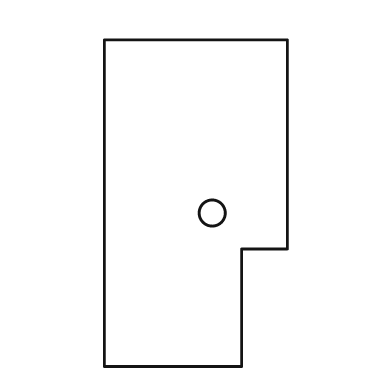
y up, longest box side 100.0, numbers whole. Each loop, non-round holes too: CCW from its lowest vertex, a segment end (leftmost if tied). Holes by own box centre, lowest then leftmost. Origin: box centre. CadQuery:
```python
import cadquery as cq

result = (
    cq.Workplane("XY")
    .moveTo(-28.0, -50.0)
    .lineTo(14.0, -50.0)
    .lineTo(14.0, -14.0)
    .lineTo(28.0, -14.0)
    .lineTo(28.0, 50.0)
    .lineTo(-28.0, 50.0)
    .close()
    .moveTo(5.0, -3.0)
    .circle(4.0)
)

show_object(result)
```